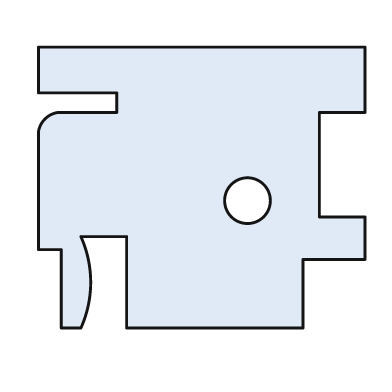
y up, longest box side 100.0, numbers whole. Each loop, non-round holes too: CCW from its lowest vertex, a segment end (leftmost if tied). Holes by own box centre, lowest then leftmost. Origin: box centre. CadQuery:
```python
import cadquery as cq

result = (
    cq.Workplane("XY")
    .moveTo(-43.0, -43.0)
    .lineTo(-37.0, -43.0)
    .threePointArc((-34.0, -29.0), (-37.0, -15.0))
    .lineTo(-23.0, -15.0)
    .lineTo(-23.0, -43.0)
    .lineTo(31.0, -43.0)
    .lineTo(31.0, -22.0)
    .lineTo(50.0, -22.0)
    .lineTo(50.0, -9.0)
    .lineTo(36.0, -9.0)
    .lineTo(36.0, 23.0)
    .lineTo(50.0, 23.0)
    .lineTo(50.0, 43.0)
    .lineTo(-50.0, 43.0)
    .lineTo(-50.0, 29.0)
    .lineTo(-26.0, 29.0)
    .lineTo(-26.0, 23.0)
    .lineTo(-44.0, 23.0)
    .threePointArc((-48.0, 21.0), (-50.0, 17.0))
    .lineTo(-50.0, -19.0)
    .lineTo(-43.0, -19.0)
    .close()
    .moveTo(14.0, -4.0)
    .circle(7.0)
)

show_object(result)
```